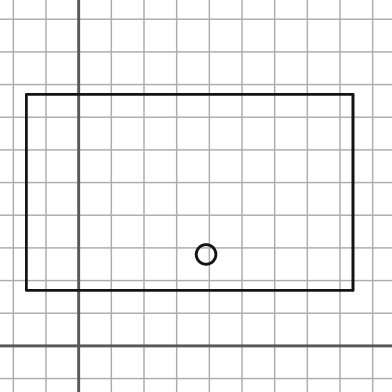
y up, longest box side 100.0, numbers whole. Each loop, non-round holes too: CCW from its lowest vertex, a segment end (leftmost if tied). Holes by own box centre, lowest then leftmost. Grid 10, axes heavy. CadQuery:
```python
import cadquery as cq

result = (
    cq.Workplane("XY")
    .moveTo(-16.0, 17.0)
    .lineTo(84.0, 17.0)
    .lineTo(84.0, 77.0)
    .lineTo(-16.0, 77.0)
    .close()
    .moveTo(39.0, 28.0)
    .circle(3.0)
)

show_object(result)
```